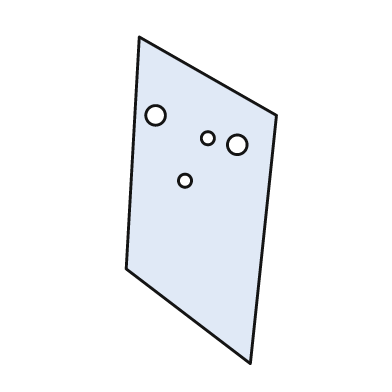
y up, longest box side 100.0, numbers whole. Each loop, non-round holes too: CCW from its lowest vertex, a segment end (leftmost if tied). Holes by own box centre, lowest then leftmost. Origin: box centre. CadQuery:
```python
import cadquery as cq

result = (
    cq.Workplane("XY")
    .moveTo(15.0, -50.0)
    .lineTo(23.0, 26.0)
    .lineTo(-19.0, 50.0)
    .lineTo(-23.0, -21.0)
    .close()
    .moveTo(-5.0, 6.0)
    .circle(2.0)
    .moveTo(11.0, 17.0)
    .circle(3.0)
    .moveTo(2.0, 19.0)
    .circle(2.0)
    .moveTo(-14.0, 26.0)
    .circle(3.0)
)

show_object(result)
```